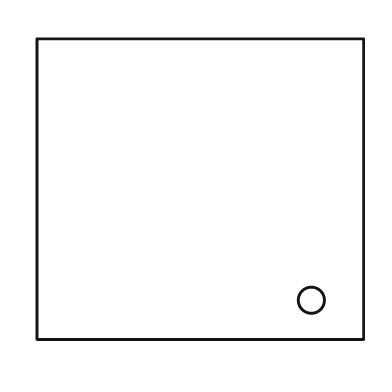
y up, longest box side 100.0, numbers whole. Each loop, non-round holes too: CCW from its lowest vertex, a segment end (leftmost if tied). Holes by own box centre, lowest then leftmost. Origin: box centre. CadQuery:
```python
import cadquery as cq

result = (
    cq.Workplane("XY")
    .moveTo(-50.0, -46.0)
    .lineTo(50.0, -46.0)
    .lineTo(50.0, 46.0)
    .lineTo(-50.0, 46.0)
    .close()
    .moveTo(34.0, -34.0)
    .circle(4.0)
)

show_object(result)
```